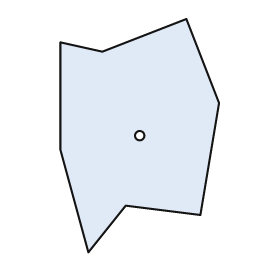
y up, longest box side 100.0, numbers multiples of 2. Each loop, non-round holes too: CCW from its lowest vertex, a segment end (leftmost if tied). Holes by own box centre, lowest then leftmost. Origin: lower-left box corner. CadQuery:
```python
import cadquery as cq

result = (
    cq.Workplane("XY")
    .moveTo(12.0, 0.0)
    .lineTo(28.0, 20.0)
    .lineTo(60.0, 16.0)
    .lineTo(68.0, 64.0)
    .lineTo(54.0, 100.0)
    .lineTo(18.0, 86.0)
    .lineTo(0.0, 90.0)
    .lineTo(0.0, 44.0)
    .close()
    .moveTo(34.0, 50.0)
    .circle(2.0)
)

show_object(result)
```